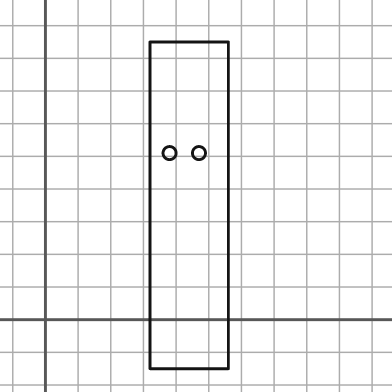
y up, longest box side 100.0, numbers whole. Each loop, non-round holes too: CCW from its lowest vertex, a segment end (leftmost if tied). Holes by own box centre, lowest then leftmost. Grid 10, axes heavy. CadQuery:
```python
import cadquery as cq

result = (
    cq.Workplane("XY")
    .moveTo(32.0, -15.0)
    .lineTo(56.0, -15.0)
    .lineTo(56.0, 85.0)
    .lineTo(32.0, 85.0)
    .close()
    .moveTo(38.0, 51.0)
    .circle(2.0)
    .moveTo(47.0, 51.0)
    .circle(2.0)
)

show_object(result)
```